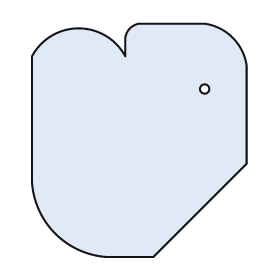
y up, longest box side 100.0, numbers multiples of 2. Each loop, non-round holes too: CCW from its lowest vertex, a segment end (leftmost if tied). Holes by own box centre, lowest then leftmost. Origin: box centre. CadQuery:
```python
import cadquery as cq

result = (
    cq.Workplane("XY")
    .moveTo(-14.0, -50.0)
    .lineTo(6.0, -50.0)
    .lineTo(46.0, -10.0)
    .lineTo(46.0, 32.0)
    .threePointArc((40.0, 44.0), (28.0, 50.0))
    .lineTo(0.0, 50.0)
    .threePointArc((-4.0, 48.0), (-6.0, 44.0))
    .lineTo(-6.0, 36.0)
    .threePointArc((-26.0, 48.0), (-46.0, 36.0))
    .lineTo(-46.0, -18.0)
    .threePointArc((-36.0, -40.0), (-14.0, -50.0))
    .close()
    .moveTo(28.0, 22.0)
    .circle(2.0)
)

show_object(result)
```